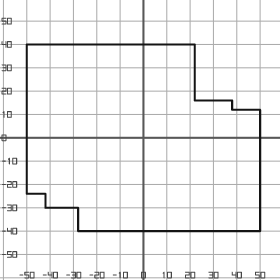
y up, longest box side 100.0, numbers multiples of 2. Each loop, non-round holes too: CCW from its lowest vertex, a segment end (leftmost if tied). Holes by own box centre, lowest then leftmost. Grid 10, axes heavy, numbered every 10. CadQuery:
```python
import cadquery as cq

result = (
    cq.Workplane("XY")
    .moveTo(-28.0, -40.0)
    .lineTo(50.0, -40.0)
    .lineTo(50.0, 12.0)
    .lineTo(38.0, 12.0)
    .lineTo(38.0, 16.0)
    .lineTo(22.0, 16.0)
    .lineTo(22.0, 40.0)
    .lineTo(-50.0, 40.0)
    .lineTo(-50.0, -24.0)
    .lineTo(-42.0, -24.0)
    .lineTo(-42.0, -30.0)
    .lineTo(-28.0, -30.0)
    .close()
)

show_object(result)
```